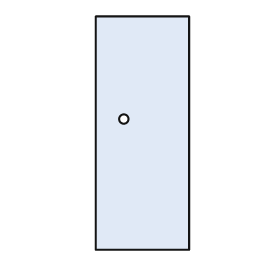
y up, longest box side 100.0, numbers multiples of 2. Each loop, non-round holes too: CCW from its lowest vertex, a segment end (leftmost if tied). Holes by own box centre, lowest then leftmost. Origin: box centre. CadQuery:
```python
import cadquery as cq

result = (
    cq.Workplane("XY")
    .moveTo(-20.0, -50.0)
    .lineTo(20.0, -50.0)
    .lineTo(20.0, 50.0)
    .lineTo(-20.0, 50.0)
    .close()
    .moveTo(-8.0, 6.0)
    .circle(2.0)
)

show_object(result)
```